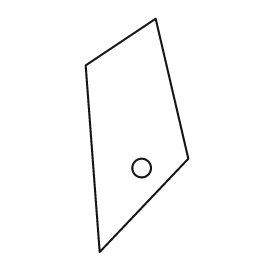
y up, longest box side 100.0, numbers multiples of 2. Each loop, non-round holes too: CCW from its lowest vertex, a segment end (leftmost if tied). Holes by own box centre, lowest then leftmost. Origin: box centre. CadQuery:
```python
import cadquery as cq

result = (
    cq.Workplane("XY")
    .moveTo(-16.0, -50.0)
    .lineTo(22.0, -10.0)
    .lineTo(8.0, 50.0)
    .lineTo(-22.0, 30.0)
    .close()
    .moveTo(2.0, -14.0)
    .circle(4.0)
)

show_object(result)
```